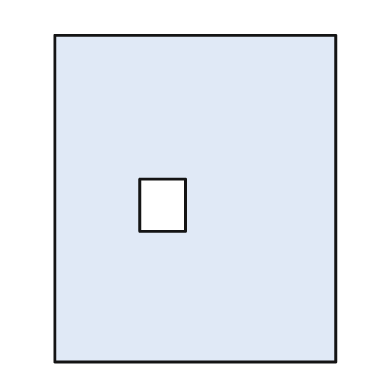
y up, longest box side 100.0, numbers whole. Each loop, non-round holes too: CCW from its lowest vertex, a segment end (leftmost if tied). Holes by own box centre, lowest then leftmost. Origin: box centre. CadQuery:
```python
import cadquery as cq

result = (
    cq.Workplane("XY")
    .moveTo(-43.0, -50.0)
    .lineTo(43.0, -50.0)
    .lineTo(43.0, 50.0)
    .lineTo(-43.0, 50.0)
    .close()
    .moveTo(-17.0, -10.0)
    .lineTo(-3.0, -10.0)
    .lineTo(-3.0, 6.0)
    .lineTo(-17.0, 6.0)
    .close()
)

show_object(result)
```